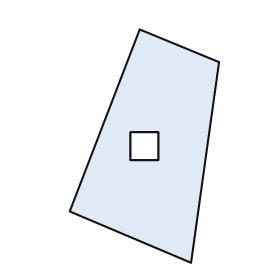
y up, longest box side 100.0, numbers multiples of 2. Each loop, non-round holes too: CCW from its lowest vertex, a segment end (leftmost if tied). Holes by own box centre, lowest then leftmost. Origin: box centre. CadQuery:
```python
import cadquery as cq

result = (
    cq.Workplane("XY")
    .moveTo(20.0, -50.0)
    .lineTo(32.0, 36.0)
    .lineTo(-2.0, 50.0)
    .lineTo(-32.0, -28.0)
    .close()
    .moveTo(-6.0, -6.0)
    .lineTo(6.0, -6.0)
    .lineTo(6.0, 6.0)
    .lineTo(-6.0, 6.0)
    .close()
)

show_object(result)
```